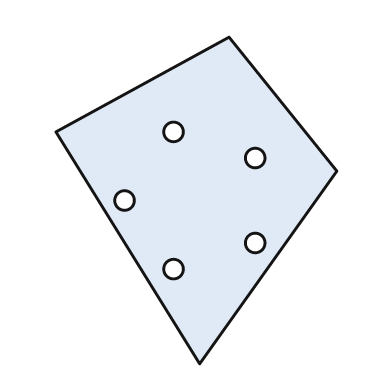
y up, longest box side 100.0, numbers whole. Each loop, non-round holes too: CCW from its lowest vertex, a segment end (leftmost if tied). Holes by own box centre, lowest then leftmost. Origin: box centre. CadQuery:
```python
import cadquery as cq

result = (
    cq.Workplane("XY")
    .moveTo(1.0, -50.0)
    .lineTo(43.0, 9.0)
    .lineTo(10.0, 50.0)
    .lineTo(-43.0, 21.0)
    .close()
    .moveTo(-7.0, -21.0)
    .circle(3.0)
    .moveTo(18.0, -13.0)
    .circle(3.0)
    .moveTo(-22.0, 0.0)
    .circle(3.0)
    .moveTo(18.0, 13.0)
    .circle(3.0)
    .moveTo(-7.0, 21.0)
    .circle(3.0)
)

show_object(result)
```